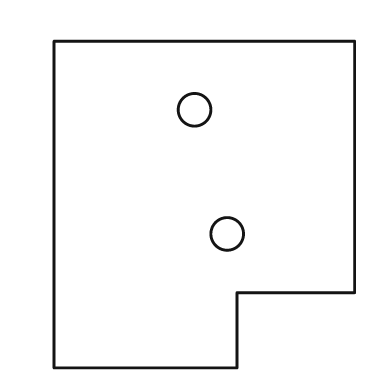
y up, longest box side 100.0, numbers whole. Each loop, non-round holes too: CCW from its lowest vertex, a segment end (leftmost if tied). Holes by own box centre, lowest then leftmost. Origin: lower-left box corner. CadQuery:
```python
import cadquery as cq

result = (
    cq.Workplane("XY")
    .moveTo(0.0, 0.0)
    .lineTo(56.0, 0.0)
    .lineTo(56.0, 23.0)
    .lineTo(92.0, 23.0)
    .lineTo(92.0, 100.0)
    .lineTo(0.0, 100.0)
    .close()
    .moveTo(53.0, 41.0)
    .circle(5.0)
    .moveTo(43.0, 79.0)
    .circle(5.0)
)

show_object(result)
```